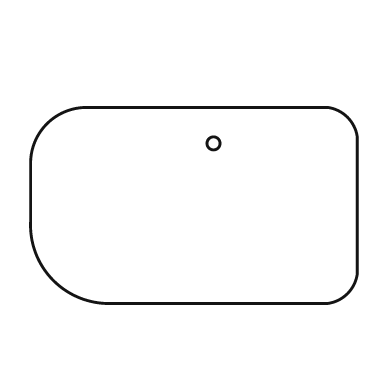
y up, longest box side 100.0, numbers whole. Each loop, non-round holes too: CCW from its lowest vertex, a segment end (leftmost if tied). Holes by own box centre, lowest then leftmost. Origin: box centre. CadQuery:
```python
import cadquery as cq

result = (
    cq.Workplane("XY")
    .moveTo(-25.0, -30.0)
    .lineTo(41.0, -30.0)
    .threePointArc((47.0, -27.0), (50.0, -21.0))
    .lineTo(50.0, 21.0)
    .threePointArc((47.0, 27.0), (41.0, 30.0))
    .lineTo(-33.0, 30.0)
    .threePointArc((-45.0, 25.0), (-50.0, 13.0))
    .lineTo(-50.0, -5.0)
    .threePointArc((-43.0, -23.0), (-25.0, -30.0))
    .close()
    .moveTo(6.0, 19.0)
    .circle(2.0)
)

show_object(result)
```